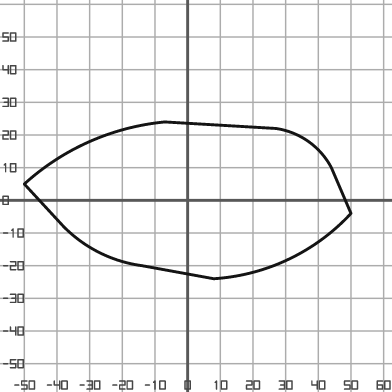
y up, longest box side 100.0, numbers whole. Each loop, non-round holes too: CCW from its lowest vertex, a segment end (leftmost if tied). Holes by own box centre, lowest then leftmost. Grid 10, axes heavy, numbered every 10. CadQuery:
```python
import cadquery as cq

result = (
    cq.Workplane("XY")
    .moveTo(8.0, -24.0)
    .threePointArc((31.0, -18.0), (50.0, -4.0))
    .lineTo(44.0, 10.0)
    .threePointArc((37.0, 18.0), (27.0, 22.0))
    .lineTo(-7.0, 24.0)
    .threePointArc((-30.0, 18.0), (-50.0, 5.0))
    .lineTo(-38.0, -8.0)
    .threePointArc((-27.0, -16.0), (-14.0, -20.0))
    .close()
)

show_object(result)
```